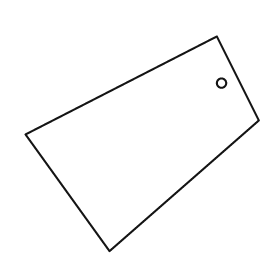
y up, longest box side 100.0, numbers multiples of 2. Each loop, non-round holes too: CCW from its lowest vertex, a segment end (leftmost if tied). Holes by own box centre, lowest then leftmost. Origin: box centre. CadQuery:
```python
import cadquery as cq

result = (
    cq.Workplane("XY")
    .moveTo(-14.0, -46.0)
    .lineTo(50.0, 10.0)
    .lineTo(32.0, 46.0)
    .lineTo(-50.0, 4.0)
    .close()
    .moveTo(34.0, 26.0)
    .circle(2.0)
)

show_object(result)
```